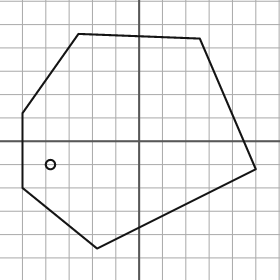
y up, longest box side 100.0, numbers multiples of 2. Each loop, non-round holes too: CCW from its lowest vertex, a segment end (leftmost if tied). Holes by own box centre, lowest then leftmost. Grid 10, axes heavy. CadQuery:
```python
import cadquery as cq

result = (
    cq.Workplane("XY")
    .moveTo(-18.0, -46.0)
    .lineTo(50.0, -12.0)
    .lineTo(26.0, 44.0)
    .lineTo(-26.0, 46.0)
    .lineTo(-50.0, 12.0)
    .lineTo(-50.0, -20.0)
    .close()
    .moveTo(-38.0, -10.0)
    .circle(2.0)
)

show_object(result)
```